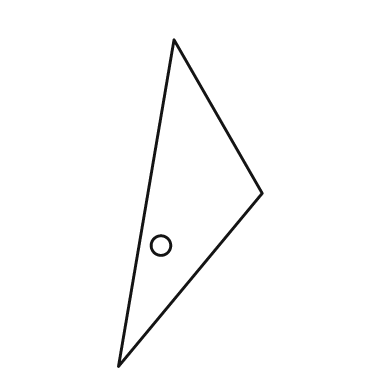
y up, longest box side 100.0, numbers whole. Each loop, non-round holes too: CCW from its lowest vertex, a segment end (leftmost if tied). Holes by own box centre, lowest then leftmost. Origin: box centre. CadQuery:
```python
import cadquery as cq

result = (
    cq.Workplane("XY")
    .moveTo(-22.0, -50.0)
    .lineTo(22.0, 3.0)
    .lineTo(-5.0, 50.0)
    .close()
    .moveTo(-9.0, -13.0)
    .circle(3.0)
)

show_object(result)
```